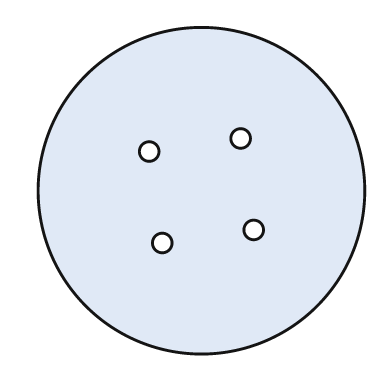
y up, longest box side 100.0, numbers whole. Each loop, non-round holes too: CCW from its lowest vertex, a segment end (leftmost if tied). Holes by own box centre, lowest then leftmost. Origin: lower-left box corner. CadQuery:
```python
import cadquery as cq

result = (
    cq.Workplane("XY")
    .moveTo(50.0, 50.0)
    .circle(50.0)
    .moveTo(38.0, 34.0)
    .circle(3.0)
    .moveTo(66.0, 38.0)
    .circle(3.0)
    .moveTo(34.0, 62.0)
    .circle(3.0)
    .moveTo(62.0, 66.0)
    .circle(3.0)
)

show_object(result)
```